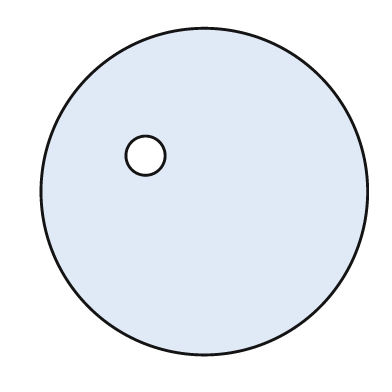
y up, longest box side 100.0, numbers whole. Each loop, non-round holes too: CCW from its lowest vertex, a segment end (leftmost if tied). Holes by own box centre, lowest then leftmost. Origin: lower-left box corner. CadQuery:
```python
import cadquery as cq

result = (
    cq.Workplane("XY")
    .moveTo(50.0, 50.0)
    .circle(50.0)
    .moveTo(32.0, 61.0)
    .circle(6.0)
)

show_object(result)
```